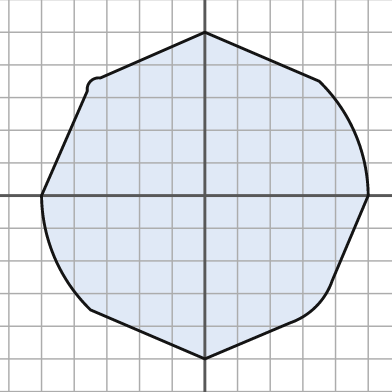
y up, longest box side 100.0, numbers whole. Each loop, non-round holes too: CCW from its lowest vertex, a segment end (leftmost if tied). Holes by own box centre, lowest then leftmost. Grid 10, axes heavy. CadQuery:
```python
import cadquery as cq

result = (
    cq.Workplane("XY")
    .moveTo(0.0, -50.0)
    .lineTo(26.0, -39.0)
    .threePointArc((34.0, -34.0), (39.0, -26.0))
    .lineTo(50.0, 0.0)
    .threePointArc((46.0, 19.0), (35.0, 35.0))
    .lineTo(0.0, 50.0)
    .lineTo(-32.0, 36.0)
    .threePointArc((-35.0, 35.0), (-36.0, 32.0))
    .lineTo(-50.0, 0.0)
    .threePointArc((-46.0, -19.0), (-35.0, -35.0))
    .close()
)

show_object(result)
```